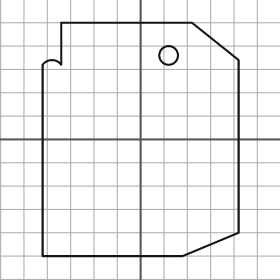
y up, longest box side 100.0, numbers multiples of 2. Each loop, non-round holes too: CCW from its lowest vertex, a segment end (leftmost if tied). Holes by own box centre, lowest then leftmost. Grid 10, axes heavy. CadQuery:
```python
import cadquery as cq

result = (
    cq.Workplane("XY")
    .moveTo(-42.0, -50.0)
    .lineTo(18.0, -50.0)
    .lineTo(42.0, -40.0)
    .lineTo(42.0, 34.0)
    .lineTo(22.0, 50.0)
    .lineTo(-34.0, 50.0)
    .lineTo(-34.0, 32.0)
    .threePointArc((-38.0, 34.0), (-42.0, 32.0))
    .close()
    .moveTo(12.0, 36.0)
    .circle(4.0)
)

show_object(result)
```